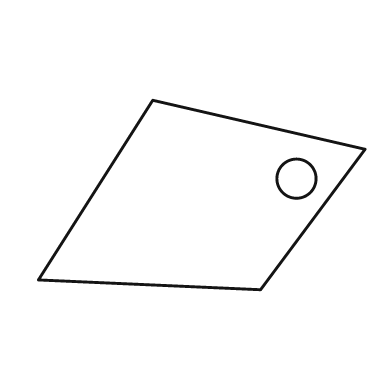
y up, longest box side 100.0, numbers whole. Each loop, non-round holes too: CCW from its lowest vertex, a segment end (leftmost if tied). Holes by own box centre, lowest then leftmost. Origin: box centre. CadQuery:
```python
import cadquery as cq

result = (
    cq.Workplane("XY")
    .moveTo(18.0, -29.0)
    .lineTo(50.0, 14.0)
    .lineTo(-15.0, 29.0)
    .lineTo(-50.0, -26.0)
    .close()
    .moveTo(29.0, 5.0)
    .circle(6.0)
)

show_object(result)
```